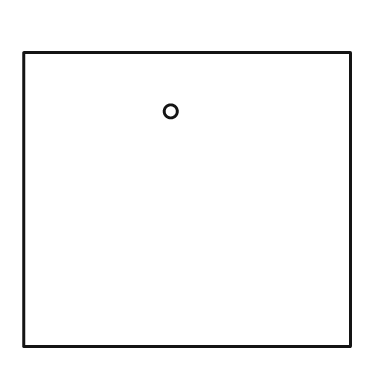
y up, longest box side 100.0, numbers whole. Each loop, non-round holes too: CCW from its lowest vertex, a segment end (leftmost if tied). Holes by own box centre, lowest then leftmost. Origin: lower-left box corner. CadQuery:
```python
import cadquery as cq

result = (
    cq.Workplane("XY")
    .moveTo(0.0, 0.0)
    .lineTo(100.0, 0.0)
    .lineTo(100.0, 90.0)
    .lineTo(0.0, 90.0)
    .close()
    .moveTo(45.0, 72.0)
    .circle(2.0)
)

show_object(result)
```